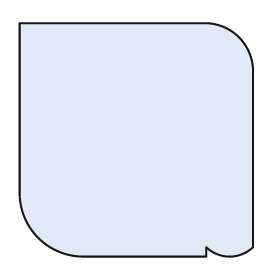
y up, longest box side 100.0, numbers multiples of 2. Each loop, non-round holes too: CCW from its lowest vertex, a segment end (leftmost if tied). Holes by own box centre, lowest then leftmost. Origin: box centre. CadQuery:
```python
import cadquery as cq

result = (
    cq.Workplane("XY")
    .moveTo(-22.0, -50.0)
    .lineTo(30.0, -50.0)
    .lineTo(30.0, -46.0)
    .threePointArc((40.0, -50.0), (50.0, -46.0))
    .lineTo(50.0, 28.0)
    .threePointArc((44.0, 44.0), (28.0, 50.0))
    .lineTo(-50.0, 50.0)
    .lineTo(-50.0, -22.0)
    .threePointArc((-42.0, -42.0), (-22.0, -50.0))
    .close()
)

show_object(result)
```